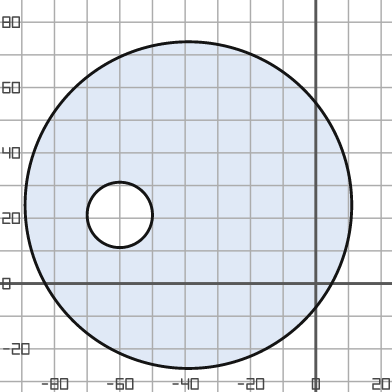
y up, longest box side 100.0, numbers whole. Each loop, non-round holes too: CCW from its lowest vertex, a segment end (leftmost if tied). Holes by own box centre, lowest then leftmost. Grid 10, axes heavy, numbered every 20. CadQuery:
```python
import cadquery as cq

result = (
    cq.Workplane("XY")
    .moveTo(-39.0, 24.0)
    .circle(50.0)
    .moveTo(-60.0, 21.0)
    .circle(10.0)
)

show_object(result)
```